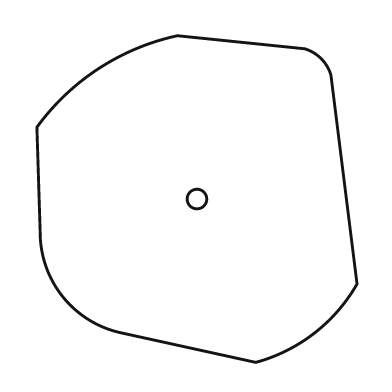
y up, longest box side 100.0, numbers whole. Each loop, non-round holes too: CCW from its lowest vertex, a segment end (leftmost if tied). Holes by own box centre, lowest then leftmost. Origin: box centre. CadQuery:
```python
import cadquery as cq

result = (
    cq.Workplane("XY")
    .moveTo(18.0, -50.0)
    .threePointArc((36.0, -41.0), (49.0, -26.0))
    .lineTo(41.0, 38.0)
    .threePointArc((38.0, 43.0), (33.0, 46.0))
    .lineTo(-6.0, 50.0)
    .threePointArc((-30.0, 40.0), (-49.0, 22.0))
    .lineTo(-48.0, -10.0)
    .threePointArc((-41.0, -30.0), (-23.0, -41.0))
    .close()
    .moveTo(0.0, 0.0)
    .circle(3.0)
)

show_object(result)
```